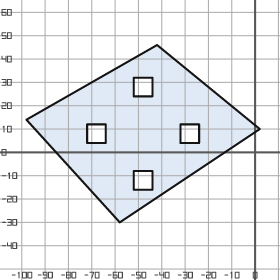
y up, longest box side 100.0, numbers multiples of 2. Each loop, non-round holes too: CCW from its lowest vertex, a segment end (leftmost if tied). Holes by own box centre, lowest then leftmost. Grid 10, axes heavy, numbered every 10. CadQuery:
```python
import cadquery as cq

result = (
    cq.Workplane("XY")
    .moveTo(-58.0, -30.0)
    .lineTo(2.0, 10.0)
    .lineTo(-42.0, 46.0)
    .lineTo(-98.0, 14.0)
    .close()
    .moveTo(-52.0, -16.0)
    .lineTo(-44.0, -16.0)
    .lineTo(-44.0, -8.0)
    .lineTo(-52.0, -8.0)
    .close()
    .moveTo(-72.0, 4.0)
    .lineTo(-64.0, 4.0)
    .lineTo(-64.0, 12.0)
    .lineTo(-72.0, 12.0)
    .close()
    .moveTo(-32.0, 4.0)
    .lineTo(-24.0, 4.0)
    .lineTo(-24.0, 12.0)
    .lineTo(-32.0, 12.0)
    .close()
    .moveTo(-52.0, 24.0)
    .lineTo(-44.0, 24.0)
    .lineTo(-44.0, 32.0)
    .lineTo(-52.0, 32.0)
    .close()
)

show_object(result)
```